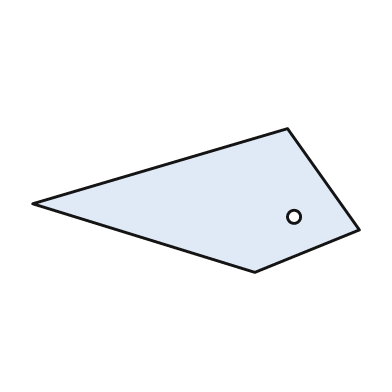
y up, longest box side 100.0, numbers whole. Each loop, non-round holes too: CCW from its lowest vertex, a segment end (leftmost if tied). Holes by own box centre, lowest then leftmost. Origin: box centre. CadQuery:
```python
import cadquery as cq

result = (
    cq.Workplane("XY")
    .moveTo(18.0, -22.0)
    .lineTo(50.0, -9.0)
    .lineTo(28.0, 22.0)
    .lineTo(-50.0, -1.0)
    .close()
    .moveTo(30.0, -5.0)
    .circle(2.0)
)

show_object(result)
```